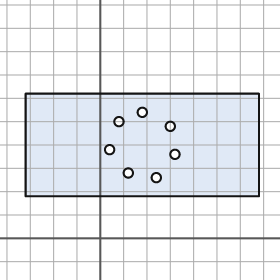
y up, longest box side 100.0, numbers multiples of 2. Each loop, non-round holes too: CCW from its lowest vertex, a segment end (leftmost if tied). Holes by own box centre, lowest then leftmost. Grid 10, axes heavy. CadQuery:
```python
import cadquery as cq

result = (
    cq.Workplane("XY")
    .moveTo(-32.0, 18.0)
    .lineTo(68.0, 18.0)
    .lineTo(68.0, 62.0)
    .lineTo(-32.0, 62.0)
    .close()
    .moveTo(24.0, 26.0)
    .circle(2.0)
    .moveTo(12.0, 28.0)
    .circle(2.0)
    .moveTo(32.0, 36.0)
    .circle(2.0)
    .moveTo(4.0, 38.0)
    .circle(2.0)
    .moveTo(30.0, 48.0)
    .circle(2.0)
    .moveTo(8.0, 50.0)
    .circle(2.0)
    .moveTo(18.0, 54.0)
    .circle(2.0)
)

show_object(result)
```